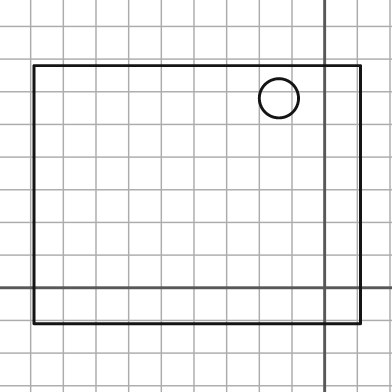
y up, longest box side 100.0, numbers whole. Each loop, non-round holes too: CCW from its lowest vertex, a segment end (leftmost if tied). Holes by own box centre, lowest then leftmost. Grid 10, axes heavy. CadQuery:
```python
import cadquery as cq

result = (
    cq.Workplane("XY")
    .moveTo(-89.0, -11.0)
    .lineTo(11.0, -11.0)
    .lineTo(11.0, 68.0)
    .lineTo(-89.0, 68.0)
    .close()
    .moveTo(-14.0, 58.0)
    .circle(6.0)
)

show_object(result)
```